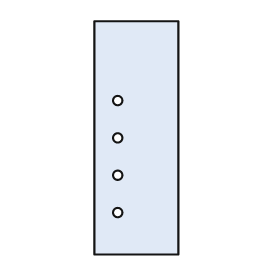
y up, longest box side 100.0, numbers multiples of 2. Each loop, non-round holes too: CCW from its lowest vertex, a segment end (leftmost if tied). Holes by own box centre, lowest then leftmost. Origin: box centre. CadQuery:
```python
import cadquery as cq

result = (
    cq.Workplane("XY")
    .moveTo(-18.0, -50.0)
    .lineTo(18.0, -50.0)
    .lineTo(18.0, 50.0)
    .lineTo(-18.0, 50.0)
    .close()
    .moveTo(-8.0, -32.0)
    .circle(2.0)
    .moveTo(-8.0, -16.0)
    .circle(2.0)
    .moveTo(-8.0, 0.0)
    .circle(2.0)
    .moveTo(-8.0, 16.0)
    .circle(2.0)
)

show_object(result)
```